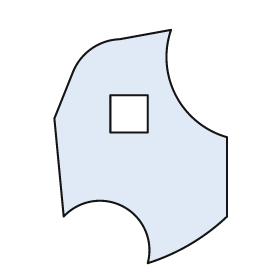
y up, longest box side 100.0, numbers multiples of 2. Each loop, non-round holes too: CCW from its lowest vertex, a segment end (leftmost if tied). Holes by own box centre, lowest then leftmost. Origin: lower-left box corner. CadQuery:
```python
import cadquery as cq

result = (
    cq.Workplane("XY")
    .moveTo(40.0, 0.0)
    .threePointArc((58.0, 8.0), (74.0, 20.0))
    .lineTo(74.0, 54.0)
    .threePointArc((52.0, 72.0), (50.0, 100.0))
    .lineTo(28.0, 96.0)
    .threePointArc((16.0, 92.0), (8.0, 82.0))
    .lineTo(0.0, 62.0)
    .lineTo(4.0, 20.0)
    .threePointArc((30.0, 24.0), (40.0, 0.0))
    .close()
    .moveTo(24.0, 56.0)
    .lineTo(40.0, 56.0)
    .lineTo(40.0, 72.0)
    .lineTo(24.0, 72.0)
    .close()
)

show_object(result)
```